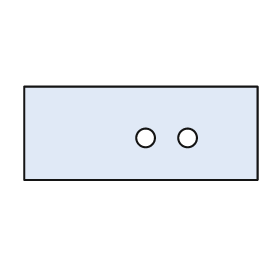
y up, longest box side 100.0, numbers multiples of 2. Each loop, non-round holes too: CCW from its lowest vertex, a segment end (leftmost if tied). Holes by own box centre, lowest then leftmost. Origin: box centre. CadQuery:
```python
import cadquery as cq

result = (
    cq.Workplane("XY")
    .moveTo(-50.0, -20.0)
    .lineTo(50.0, -20.0)
    .lineTo(50.0, 20.0)
    .lineTo(-50.0, 20.0)
    .close()
    .moveTo(2.0, -2.0)
    .circle(4.0)
    .moveTo(20.0, -2.0)
    .circle(4.0)
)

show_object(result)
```